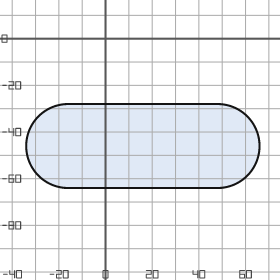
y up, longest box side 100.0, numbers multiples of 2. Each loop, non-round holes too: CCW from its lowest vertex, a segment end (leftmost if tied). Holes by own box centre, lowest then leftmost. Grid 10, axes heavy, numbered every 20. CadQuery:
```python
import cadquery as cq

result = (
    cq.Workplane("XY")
    .moveTo(-16.0, -64.0)
    .lineTo(48.0, -64.0)
    .threePointArc((66.0, -46.0), (48.0, -28.0))
    .lineTo(-16.0, -28.0)
    .threePointArc((-34.0, -46.0), (-16.0, -64.0))
    .close()
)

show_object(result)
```